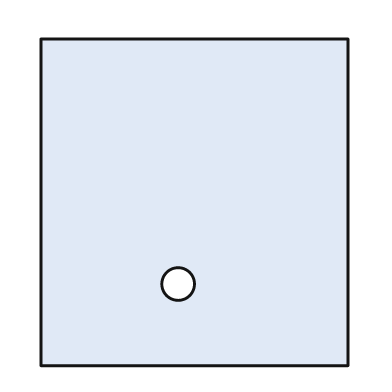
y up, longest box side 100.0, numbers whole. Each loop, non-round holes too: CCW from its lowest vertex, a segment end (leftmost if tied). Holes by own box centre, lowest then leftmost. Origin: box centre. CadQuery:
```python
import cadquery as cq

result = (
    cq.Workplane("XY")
    .moveTo(-47.0, -50.0)
    .lineTo(47.0, -50.0)
    .lineTo(47.0, 50.0)
    .lineTo(-47.0, 50.0)
    .close()
    .moveTo(-5.0, -25.0)
    .circle(5.0)
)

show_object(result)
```